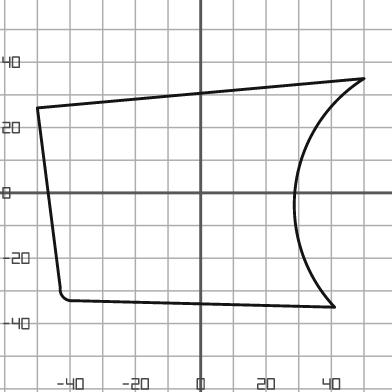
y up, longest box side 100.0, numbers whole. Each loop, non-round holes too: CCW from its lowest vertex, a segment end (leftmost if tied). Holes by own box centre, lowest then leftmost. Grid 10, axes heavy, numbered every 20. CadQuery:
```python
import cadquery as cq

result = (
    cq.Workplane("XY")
    .moveTo(41.0, -35.0)
    .threePointArc((29.0, 2.0), (50.0, 35.0))
    .lineTo(-50.0, 26.0)
    .lineTo(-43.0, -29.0)
    .threePointArc((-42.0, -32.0), (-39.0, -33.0))
    .close()
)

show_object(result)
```